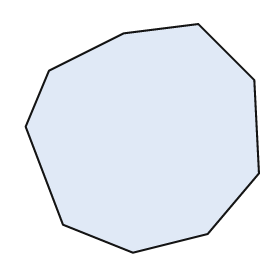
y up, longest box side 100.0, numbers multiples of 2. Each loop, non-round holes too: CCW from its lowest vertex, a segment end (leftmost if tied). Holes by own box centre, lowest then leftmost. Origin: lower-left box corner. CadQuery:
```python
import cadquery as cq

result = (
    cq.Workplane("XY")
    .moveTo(46.0, 0.0)
    .lineTo(78.0, 8.0)
    .lineTo(100.0, 34.0)
    .lineTo(98.0, 74.0)
    .lineTo(74.0, 98.0)
    .lineTo(42.0, 94.0)
    .lineTo(10.0, 78.0)
    .lineTo(0.0, 54.0)
    .lineTo(16.0, 12.0)
    .close()
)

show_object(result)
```